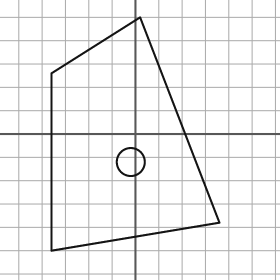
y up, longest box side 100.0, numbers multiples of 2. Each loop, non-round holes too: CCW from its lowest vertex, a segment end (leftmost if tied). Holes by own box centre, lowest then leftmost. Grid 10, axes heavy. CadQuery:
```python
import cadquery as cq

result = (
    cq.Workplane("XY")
    .moveTo(-36.0, -50.0)
    .lineTo(36.0, -38.0)
    .lineTo(2.0, 50.0)
    .lineTo(-36.0, 26.0)
    .close()
    .moveTo(-2.0, -12.0)
    .circle(6.0)
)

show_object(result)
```